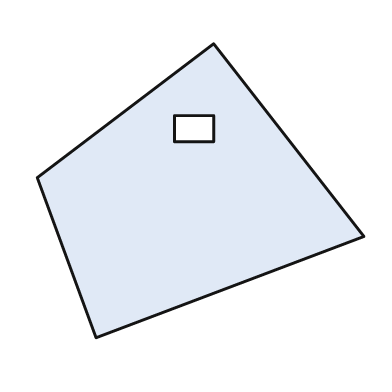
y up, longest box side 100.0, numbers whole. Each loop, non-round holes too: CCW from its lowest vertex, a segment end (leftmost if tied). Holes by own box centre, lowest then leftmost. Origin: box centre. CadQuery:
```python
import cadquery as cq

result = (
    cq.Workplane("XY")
    .moveTo(-32.0, -45.0)
    .lineTo(50.0, -14.0)
    .lineTo(4.0, 45.0)
    .lineTo(-50.0, 4.0)
    .close()
    .moveTo(-8.0, 15.0)
    .lineTo(4.0, 15.0)
    .lineTo(4.0, 23.0)
    .lineTo(-8.0, 23.0)
    .close()
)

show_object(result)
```